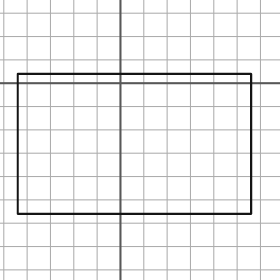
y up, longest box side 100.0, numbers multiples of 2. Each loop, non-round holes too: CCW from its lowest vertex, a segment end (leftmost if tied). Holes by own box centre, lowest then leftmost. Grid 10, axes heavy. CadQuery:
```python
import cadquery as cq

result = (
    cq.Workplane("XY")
    .moveTo(-44.0, -56.0)
    .lineTo(56.0, -56.0)
    .lineTo(56.0, 4.0)
    .lineTo(-44.0, 4.0)
    .close()
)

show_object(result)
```